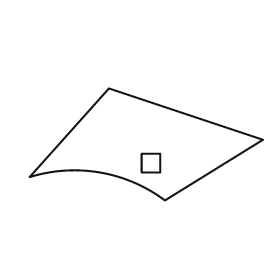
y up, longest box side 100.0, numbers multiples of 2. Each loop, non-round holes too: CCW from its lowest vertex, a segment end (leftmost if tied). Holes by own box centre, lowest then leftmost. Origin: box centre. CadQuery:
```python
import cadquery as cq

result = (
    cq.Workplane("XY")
    .moveTo(8.0, -24.0)
    .lineTo(50.0, 2.0)
    .lineTo(-16.0, 24.0)
    .lineTo(-50.0, -14.0)
    .threePointArc((-20.0, -12.0), (8.0, -24.0))
    .close()
    .moveTo(-2.0, -12.0)
    .lineTo(6.0, -12.0)
    .lineTo(6.0, -4.0)
    .lineTo(-2.0, -4.0)
    .close()
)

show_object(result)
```